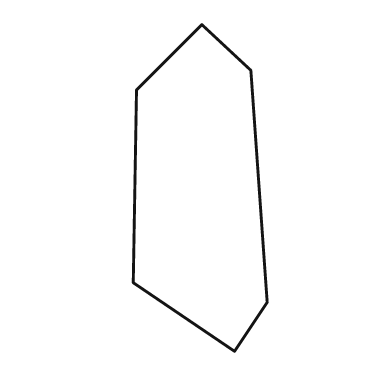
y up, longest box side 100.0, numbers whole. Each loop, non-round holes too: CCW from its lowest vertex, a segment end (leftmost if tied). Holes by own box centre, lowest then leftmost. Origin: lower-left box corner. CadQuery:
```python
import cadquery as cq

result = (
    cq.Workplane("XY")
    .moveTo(31.0, 0.0)
    .lineTo(41.0, 15.0)
    .lineTo(36.0, 86.0)
    .lineTo(21.0, 100.0)
    .lineTo(1.0, 80.0)
    .lineTo(0.0, 21.0)
    .close()
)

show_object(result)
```